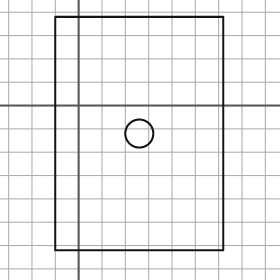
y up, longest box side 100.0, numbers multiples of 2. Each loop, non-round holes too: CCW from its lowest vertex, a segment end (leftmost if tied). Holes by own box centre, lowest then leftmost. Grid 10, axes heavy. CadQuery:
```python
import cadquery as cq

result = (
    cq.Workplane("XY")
    .moveTo(-10.0, -62.0)
    .lineTo(62.0, -62.0)
    .lineTo(62.0, 38.0)
    .lineTo(-10.0, 38.0)
    .close()
    .moveTo(26.0, -12.0)
    .circle(6.0)
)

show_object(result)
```